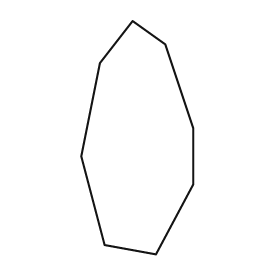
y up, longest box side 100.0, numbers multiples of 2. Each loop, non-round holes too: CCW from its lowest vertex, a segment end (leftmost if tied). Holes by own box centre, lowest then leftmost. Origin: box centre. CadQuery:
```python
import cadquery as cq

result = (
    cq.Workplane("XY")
    .moveTo(8.0, -50.0)
    .lineTo(24.0, -20.0)
    .lineTo(24.0, 4.0)
    .lineTo(12.0, 40.0)
    .lineTo(-2.0, 50.0)
    .lineTo(-16.0, 32.0)
    .lineTo(-24.0, -8.0)
    .lineTo(-14.0, -46.0)
    .close()
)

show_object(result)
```